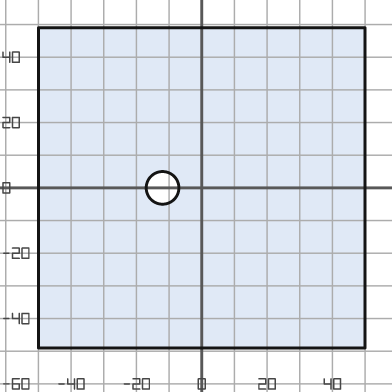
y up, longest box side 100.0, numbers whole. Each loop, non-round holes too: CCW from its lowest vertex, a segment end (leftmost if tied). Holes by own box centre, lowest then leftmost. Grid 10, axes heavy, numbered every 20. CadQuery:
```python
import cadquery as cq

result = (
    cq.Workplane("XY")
    .moveTo(-50.0, -49.0)
    .lineTo(50.0, -49.0)
    .lineTo(50.0, 49.0)
    .lineTo(-50.0, 49.0)
    .close()
    .moveTo(-12.0, 0.0)
    .circle(5.0)
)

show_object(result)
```